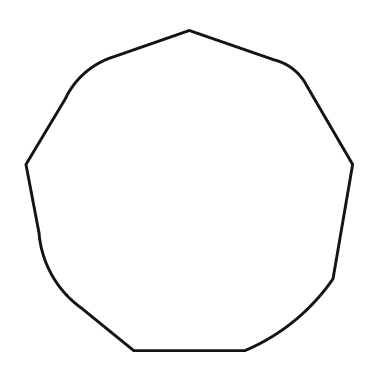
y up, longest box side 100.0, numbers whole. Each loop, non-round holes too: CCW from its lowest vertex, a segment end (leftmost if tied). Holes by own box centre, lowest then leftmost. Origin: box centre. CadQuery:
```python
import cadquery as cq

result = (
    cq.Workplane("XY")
    .moveTo(-17.0, -49.0)
    .lineTo(17.0, -49.0)
    .threePointArc((32.0, -40.0), (44.0, -27.0))
    .lineTo(50.0, 8.0)
    .lineTo(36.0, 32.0)
    .threePointArc((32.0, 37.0), (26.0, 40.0))
    .lineTo(0.0, 49.0)
    .lineTo(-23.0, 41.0)
    .threePointArc((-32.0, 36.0), (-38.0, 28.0))
    .lineTo(-50.0, 8.0)
    .lineTo(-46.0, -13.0)
    .threePointArc((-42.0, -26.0), (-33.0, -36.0))
    .close()
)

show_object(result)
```